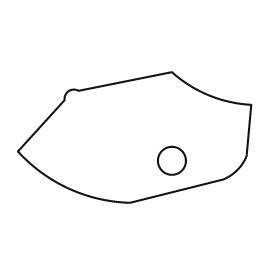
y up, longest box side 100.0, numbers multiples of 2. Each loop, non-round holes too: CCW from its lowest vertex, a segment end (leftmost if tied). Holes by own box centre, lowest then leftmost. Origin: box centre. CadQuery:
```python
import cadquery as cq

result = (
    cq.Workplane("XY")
    .moveTo(-2.0, -28.0)
    .lineTo(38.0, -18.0)
    .threePointArc((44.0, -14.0), (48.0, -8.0))
    .lineTo(50.0, 14.0)
    .threePointArc((32.0, 18.0), (16.0, 28.0))
    .lineTo(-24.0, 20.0)
    .threePointArc((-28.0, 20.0), (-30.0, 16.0))
    .lineTo(-50.0, -6.0)
    .threePointArc((-28.0, -22.0), (-2.0, -28.0))
    .close()
    .moveTo(16.0, -10.0)
    .circle(6.0)
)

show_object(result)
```